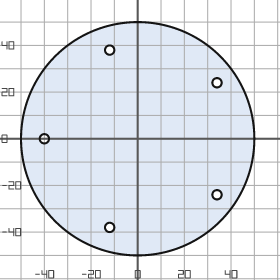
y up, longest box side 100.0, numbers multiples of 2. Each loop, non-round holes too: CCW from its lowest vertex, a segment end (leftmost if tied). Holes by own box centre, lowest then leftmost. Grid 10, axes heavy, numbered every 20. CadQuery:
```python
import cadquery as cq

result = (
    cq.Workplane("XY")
    .moveTo(0.0, 0.0)
    .circle(50.0)
    .moveTo(-12.0, -38.0)
    .circle(2.0)
    .moveTo(34.0, -24.0)
    .circle(2.0)
    .moveTo(-40.0, 0.0)
    .circle(2.0)
    .moveTo(34.0, 24.0)
    .circle(2.0)
    .moveTo(-12.0, 38.0)
    .circle(2.0)
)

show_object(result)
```